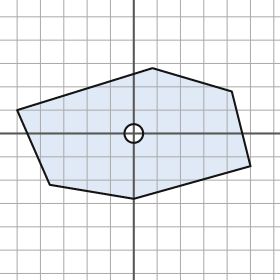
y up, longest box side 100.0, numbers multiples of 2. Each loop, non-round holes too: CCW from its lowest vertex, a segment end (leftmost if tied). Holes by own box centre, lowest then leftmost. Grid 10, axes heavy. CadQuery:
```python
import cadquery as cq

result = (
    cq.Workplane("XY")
    .moveTo(0.0, -28.0)
    .lineTo(50.0, -14.0)
    .lineTo(42.0, 18.0)
    .lineTo(8.0, 28.0)
    .lineTo(-50.0, 10.0)
    .lineTo(-36.0, -22.0)
    .close()
    .moveTo(0.0, 0.0)
    .circle(4.0)
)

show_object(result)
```